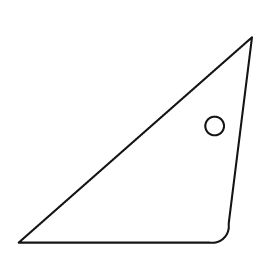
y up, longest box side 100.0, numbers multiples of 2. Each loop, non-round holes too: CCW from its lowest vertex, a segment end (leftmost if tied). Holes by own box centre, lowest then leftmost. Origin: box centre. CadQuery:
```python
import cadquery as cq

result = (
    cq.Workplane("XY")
    .moveTo(-50.0, -44.0)
    .lineTo(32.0, -44.0)
    .threePointArc((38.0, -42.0), (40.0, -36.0))
    .lineTo(50.0, 44.0)
    .close()
    .moveTo(34.0, 6.0)
    .circle(4.0)
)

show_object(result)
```